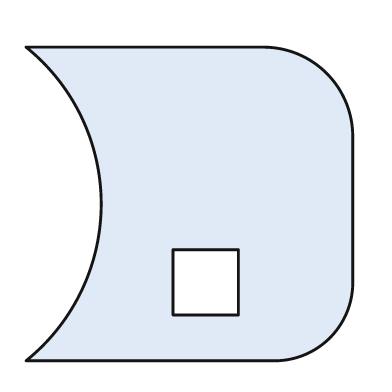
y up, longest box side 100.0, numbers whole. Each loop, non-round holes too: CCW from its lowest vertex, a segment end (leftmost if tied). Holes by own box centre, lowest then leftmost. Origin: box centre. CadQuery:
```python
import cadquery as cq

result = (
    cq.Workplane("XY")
    .moveTo(-50.0, -48.0)
    .lineTo(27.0, -48.0)
    .threePointArc((43.0, -41.0), (50.0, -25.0))
    .lineTo(50.0, 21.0)
    .threePointArc((42.0, 40.0), (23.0, 48.0))
    .lineTo(-50.0, 48.0)
    .threePointArc((-27.0, 0.0), (-50.0, -48.0))
    .close()
    .moveTo(-5.0, -34.0)
    .lineTo(15.0, -34.0)
    .lineTo(15.0, -14.0)
    .lineTo(-5.0, -14.0)
    .close()
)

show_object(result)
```